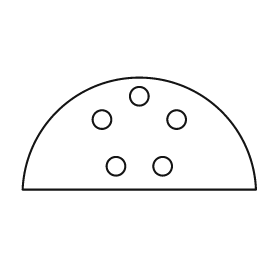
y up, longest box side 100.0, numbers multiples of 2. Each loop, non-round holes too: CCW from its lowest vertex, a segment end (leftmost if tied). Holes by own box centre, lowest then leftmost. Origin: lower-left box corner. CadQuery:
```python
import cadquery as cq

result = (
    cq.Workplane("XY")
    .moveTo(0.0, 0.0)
    .lineTo(100.0, 0.0)
    .threePointArc((50.0, 48.0), (0.0, 0.0))
    .close()
    .moveTo(40.0, 10.0)
    .circle(4.0)
    .moveTo(60.0, 10.0)
    .circle(4.0)
    .moveTo(34.0, 30.0)
    .circle(4.0)
    .moveTo(66.0, 30.0)
    .circle(4.0)
    .moveTo(50.0, 40.0)
    .circle(4.0)
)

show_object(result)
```